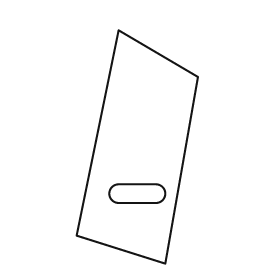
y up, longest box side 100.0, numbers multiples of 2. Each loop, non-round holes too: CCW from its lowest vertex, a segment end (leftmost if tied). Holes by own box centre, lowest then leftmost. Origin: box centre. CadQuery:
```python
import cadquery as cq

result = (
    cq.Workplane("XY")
    .moveTo(12.0, -50.0)
    .lineTo(26.0, 30.0)
    .lineTo(-8.0, 50.0)
    .lineTo(-26.0, -38.0)
    .close()
    .moveTo(-8.0, -24.0)
    .lineTo(8.0, -24.0)
    .threePointArc((12.0, -20.0), (8.0, -16.0))
    .lineTo(-8.0, -16.0)
    .threePointArc((-12.0, -20.0), (-8.0, -24.0))
    .close()
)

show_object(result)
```